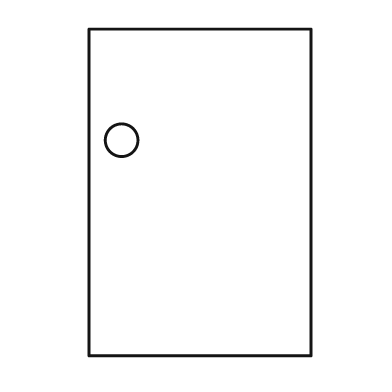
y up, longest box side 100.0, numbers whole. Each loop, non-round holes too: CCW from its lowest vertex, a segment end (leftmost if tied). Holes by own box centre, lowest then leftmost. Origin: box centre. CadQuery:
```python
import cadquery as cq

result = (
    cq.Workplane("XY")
    .moveTo(-34.0, -50.0)
    .lineTo(34.0, -50.0)
    .lineTo(34.0, 50.0)
    .lineTo(-34.0, 50.0)
    .close()
    .moveTo(-24.0, 16.0)
    .circle(5.0)
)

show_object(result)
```